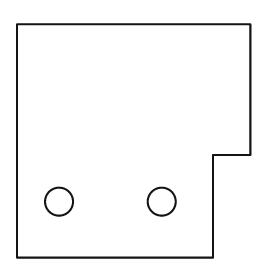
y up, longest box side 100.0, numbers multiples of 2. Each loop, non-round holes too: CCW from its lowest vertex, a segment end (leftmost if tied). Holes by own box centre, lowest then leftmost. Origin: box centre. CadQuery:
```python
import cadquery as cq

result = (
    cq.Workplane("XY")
    .moveTo(-50.0, -50.0)
    .lineTo(34.0, -50.0)
    .lineTo(34.0, -6.0)
    .lineTo(50.0, -6.0)
    .lineTo(50.0, 50.0)
    .lineTo(-50.0, 50.0)
    .close()
    .moveTo(-32.0, -26.0)
    .circle(6.0)
    .moveTo(12.0, -26.0)
    .circle(6.0)
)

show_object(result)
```